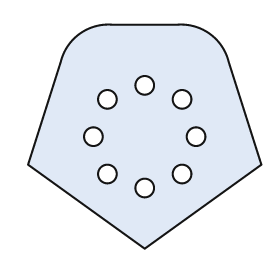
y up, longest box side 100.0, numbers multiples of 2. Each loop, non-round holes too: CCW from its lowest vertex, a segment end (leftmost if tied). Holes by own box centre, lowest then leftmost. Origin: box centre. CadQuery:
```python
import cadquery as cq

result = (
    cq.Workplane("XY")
    .moveTo(0.0, -48.0)
    .lineTo(50.0, -12.0)
    .lineTo(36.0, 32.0)
    .threePointArc((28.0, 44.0), (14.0, 48.0))
    .lineTo(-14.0, 48.0)
    .threePointArc((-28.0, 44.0), (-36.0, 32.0))
    .lineTo(-50.0, -12.0)
    .close()
    .moveTo(0.0, -22.0)
    .circle(4.0)
    .moveTo(-16.0, -16.0)
    .circle(4.0)
    .moveTo(16.0, -16.0)
    .circle(4.0)
    .moveTo(-22.0, 0.0)
    .circle(4.0)
    .moveTo(22.0, 0.0)
    .circle(4.0)
    .moveTo(-16.0, 16.0)
    .circle(4.0)
    .moveTo(16.0, 16.0)
    .circle(4.0)
    .moveTo(0.0, 22.0)
    .circle(4.0)
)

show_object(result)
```